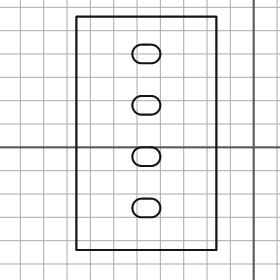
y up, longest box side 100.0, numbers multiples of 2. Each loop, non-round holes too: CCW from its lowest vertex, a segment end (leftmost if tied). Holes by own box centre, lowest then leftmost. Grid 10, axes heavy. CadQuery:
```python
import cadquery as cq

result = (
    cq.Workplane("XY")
    .moveTo(-76.0, -44.0)
    .lineTo(-16.0, -44.0)
    .lineTo(-16.0, 56.0)
    .lineTo(-76.0, 56.0)
    .close()
    .moveTo(-48.0, -30.0)
    .lineTo(-44.0, -30.0)
    .threePointArc((-40.0, -26.0), (-44.0, -22.0))
    .lineTo(-48.0, -22.0)
    .threePointArc((-52.0, -26.0), (-48.0, -30.0))
    .close()
    .moveTo(-48.0, -8.0)
    .lineTo(-44.0, -8.0)
    .threePointArc((-40.0, -4.0), (-44.0, 0.0))
    .lineTo(-48.0, 0.0)
    .threePointArc((-52.0, -4.0), (-48.0, -8.0))
    .close()
    .moveTo(-48.0, 14.0)
    .lineTo(-44.0, 14.0)
    .threePointArc((-40.0, 18.0), (-44.0, 22.0))
    .lineTo(-48.0, 22.0)
    .threePointArc((-52.0, 18.0), (-48.0, 14.0))
    .close()
    .moveTo(-48.0, 36.0)
    .lineTo(-44.0, 36.0)
    .threePointArc((-40.0, 40.0), (-44.0, 44.0))
    .lineTo(-48.0, 44.0)
    .threePointArc((-52.0, 40.0), (-48.0, 36.0))
    .close()
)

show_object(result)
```